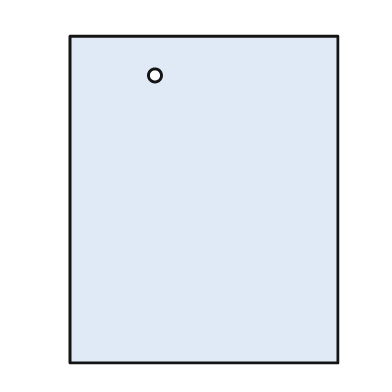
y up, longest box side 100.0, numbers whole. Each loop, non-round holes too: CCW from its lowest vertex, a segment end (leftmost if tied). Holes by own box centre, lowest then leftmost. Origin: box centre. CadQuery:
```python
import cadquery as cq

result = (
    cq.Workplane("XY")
    .moveTo(-41.0, -50.0)
    .lineTo(41.0, -50.0)
    .lineTo(41.0, 50.0)
    .lineTo(-41.0, 50.0)
    .close()
    .moveTo(-15.0, 38.0)
    .circle(2.0)
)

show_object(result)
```